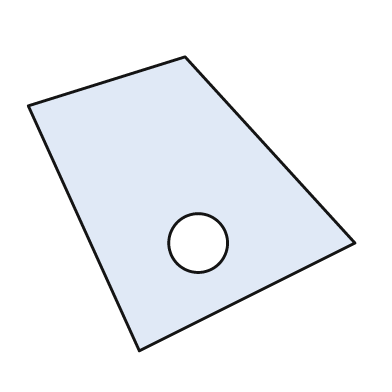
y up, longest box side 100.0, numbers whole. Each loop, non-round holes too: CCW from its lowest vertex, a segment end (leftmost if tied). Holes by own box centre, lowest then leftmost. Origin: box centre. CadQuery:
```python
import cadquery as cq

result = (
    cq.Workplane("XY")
    .moveTo(-16.0, -45.0)
    .lineTo(50.0, -12.0)
    .lineTo(-2.0, 45.0)
    .lineTo(-50.0, 30.0)
    .close()
    .moveTo(2.0, -12.0)
    .circle(9.0)
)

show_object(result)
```